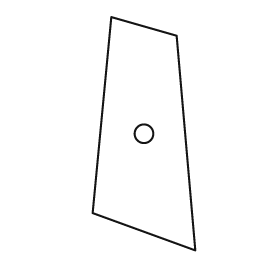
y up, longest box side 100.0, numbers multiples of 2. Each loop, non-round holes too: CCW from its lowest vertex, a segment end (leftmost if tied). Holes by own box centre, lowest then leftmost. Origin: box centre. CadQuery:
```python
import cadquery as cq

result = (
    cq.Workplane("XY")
    .moveTo(22.0, -50.0)
    .lineTo(14.0, 42.0)
    .lineTo(-14.0, 50.0)
    .lineTo(-22.0, -34.0)
    .close()
    .moveTo(0.0, 0.0)
    .circle(4.0)
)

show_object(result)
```